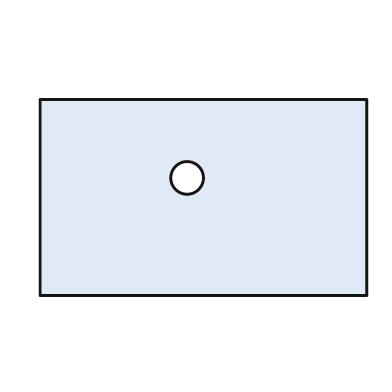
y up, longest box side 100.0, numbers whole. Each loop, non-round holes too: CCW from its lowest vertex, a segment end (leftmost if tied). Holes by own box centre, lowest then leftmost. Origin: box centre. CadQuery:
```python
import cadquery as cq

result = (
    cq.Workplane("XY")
    .moveTo(-50.0, -30.0)
    .lineTo(50.0, -30.0)
    .lineTo(50.0, 30.0)
    .lineTo(-50.0, 30.0)
    .close()
    .moveTo(-5.0, 6.0)
    .circle(5.0)
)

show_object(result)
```